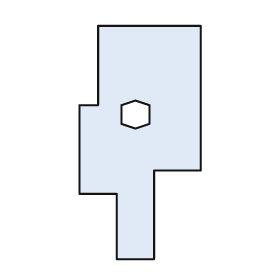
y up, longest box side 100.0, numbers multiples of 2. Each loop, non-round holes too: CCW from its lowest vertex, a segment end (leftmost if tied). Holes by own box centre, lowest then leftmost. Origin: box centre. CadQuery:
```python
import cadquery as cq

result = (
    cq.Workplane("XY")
    .moveTo(-10.0, -50.0)
    .lineTo(6.0, -50.0)
    .lineTo(6.0, -12.0)
    .lineTo(26.0, -12.0)
    .lineTo(26.0, 50.0)
    .lineTo(-18.0, 50.0)
    .lineTo(-18.0, 16.0)
    .lineTo(-26.0, 16.0)
    .lineTo(-26.0, -22.0)
    .lineTo(-10.0, -22.0)
    .close()
    .moveTo(-2.0, 6.0)
    .lineTo(4.0, 8.0)
    .lineTo(4.0, 16.0)
    .lineTo(-2.0, 18.0)
    .lineTo(-8.0, 16.0)
    .lineTo(-8.0, 8.0)
    .close()
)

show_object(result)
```